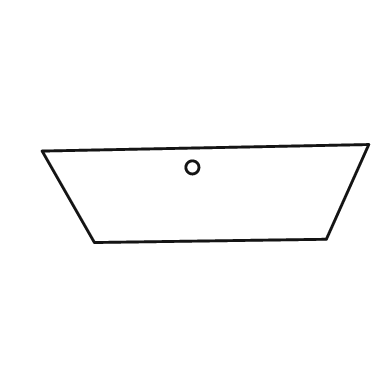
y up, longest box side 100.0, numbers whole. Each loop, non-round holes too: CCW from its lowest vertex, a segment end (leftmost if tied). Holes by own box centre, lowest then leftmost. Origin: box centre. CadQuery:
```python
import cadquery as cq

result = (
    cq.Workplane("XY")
    .moveTo(-34.0, -15.0)
    .lineTo(37.0, -14.0)
    .lineTo(50.0, 15.0)
    .lineTo(-50.0, 13.0)
    .close()
    .moveTo(-4.0, 8.0)
    .circle(2.0)
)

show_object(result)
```